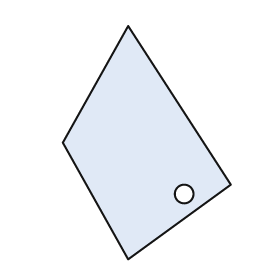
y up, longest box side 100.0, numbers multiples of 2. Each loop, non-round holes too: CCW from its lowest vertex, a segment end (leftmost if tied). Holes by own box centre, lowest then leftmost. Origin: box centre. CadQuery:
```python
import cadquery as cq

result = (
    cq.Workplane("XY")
    .moveTo(-8.0, -50.0)
    .lineTo(36.0, -18.0)
    .lineTo(-8.0, 50.0)
    .lineTo(-36.0, 0.0)
    .close()
    .moveTo(16.0, -22.0)
    .circle(4.0)
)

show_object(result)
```